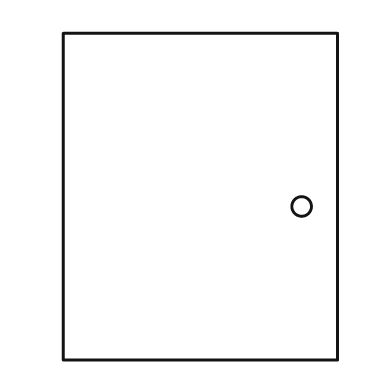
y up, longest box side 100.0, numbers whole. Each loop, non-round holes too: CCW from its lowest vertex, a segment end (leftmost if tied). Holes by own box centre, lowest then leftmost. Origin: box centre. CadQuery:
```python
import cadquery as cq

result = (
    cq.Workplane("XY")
    .moveTo(-42.0, -50.0)
    .lineTo(42.0, -50.0)
    .lineTo(42.0, 50.0)
    .lineTo(-42.0, 50.0)
    .close()
    .moveTo(31.0, -3.0)
    .circle(3.0)
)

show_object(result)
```